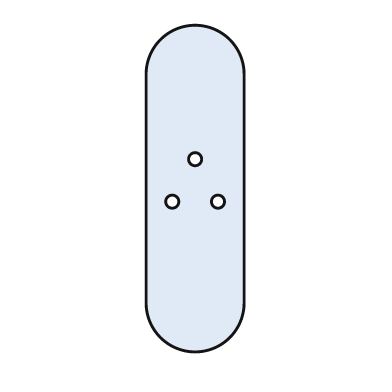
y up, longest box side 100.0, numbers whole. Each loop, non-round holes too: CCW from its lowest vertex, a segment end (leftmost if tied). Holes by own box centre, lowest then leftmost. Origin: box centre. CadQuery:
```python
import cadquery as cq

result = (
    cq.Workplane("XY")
    .moveTo(-15.0, -35.0)
    .threePointArc((0.0, -50.0), (15.0, -35.0))
    .lineTo(15.0, 35.0)
    .threePointArc((0.0, 50.0), (-15.0, 35.0))
    .close()
    .moveTo(-7.0, -4.0)
    .circle(2.0)
    .moveTo(7.0, -4.0)
    .circle(2.0)
    .moveTo(0.0, 9.0)
    .circle(2.0)
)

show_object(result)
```